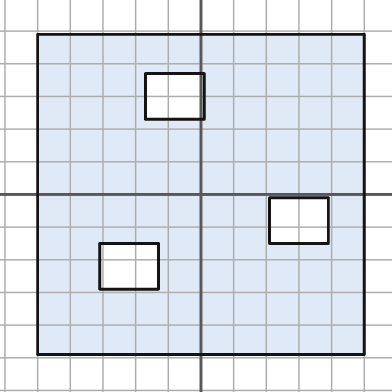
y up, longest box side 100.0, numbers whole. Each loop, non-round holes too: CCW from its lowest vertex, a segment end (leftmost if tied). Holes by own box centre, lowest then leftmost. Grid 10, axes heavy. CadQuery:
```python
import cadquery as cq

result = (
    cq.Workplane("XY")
    .moveTo(-50.0, -49.0)
    .lineTo(50.0, -49.0)
    .lineTo(50.0, 49.0)
    .lineTo(-50.0, 49.0)
    .close()
    .moveTo(-31.0, -29.0)
    .lineTo(-13.0, -29.0)
    .lineTo(-13.0, -15.0)
    .lineTo(-31.0, -15.0)
    .close()
    .moveTo(21.0, -15.0)
    .lineTo(39.0, -15.0)
    .lineTo(39.0, -1.0)
    .lineTo(21.0, -1.0)
    .close()
    .moveTo(-17.0, 23.0)
    .lineTo(1.0, 23.0)
    .lineTo(1.0, 37.0)
    .lineTo(-17.0, 37.0)
    .close()
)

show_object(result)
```